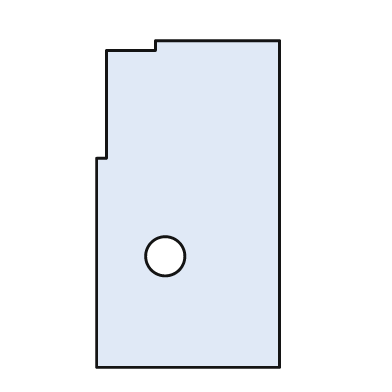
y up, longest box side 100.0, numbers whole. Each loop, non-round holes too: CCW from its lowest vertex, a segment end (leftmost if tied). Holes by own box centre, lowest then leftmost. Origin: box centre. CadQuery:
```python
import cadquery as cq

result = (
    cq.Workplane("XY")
    .moveTo(-28.0, -50.0)
    .lineTo(28.0, -50.0)
    .lineTo(28.0, 50.0)
    .lineTo(-10.0, 50.0)
    .lineTo(-10.0, 47.0)
    .lineTo(-25.0, 47.0)
    .lineTo(-25.0, 14.0)
    .lineTo(-28.0, 14.0)
    .close()
    .moveTo(-7.0, -16.0)
    .circle(6.0)
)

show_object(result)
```